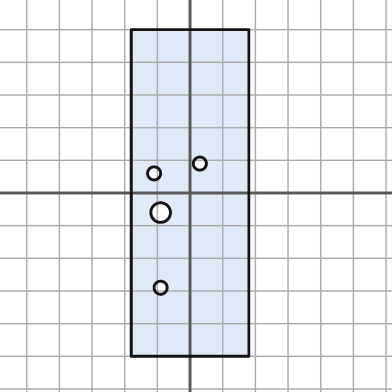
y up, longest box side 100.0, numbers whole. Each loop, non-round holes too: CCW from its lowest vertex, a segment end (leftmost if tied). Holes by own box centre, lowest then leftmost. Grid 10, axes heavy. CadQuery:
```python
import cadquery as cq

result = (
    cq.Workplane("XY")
    .moveTo(-18.0, -50.0)
    .lineTo(18.0, -50.0)
    .lineTo(18.0, 50.0)
    .lineTo(-18.0, 50.0)
    .close()
    .moveTo(-9.0, -29.0)
    .circle(2.0)
    .moveTo(-9.0, -6.0)
    .circle(3.0)
    .moveTo(-11.0, 6.0)
    .circle(2.0)
    .moveTo(3.0, 9.0)
    .circle(2.0)
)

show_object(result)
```